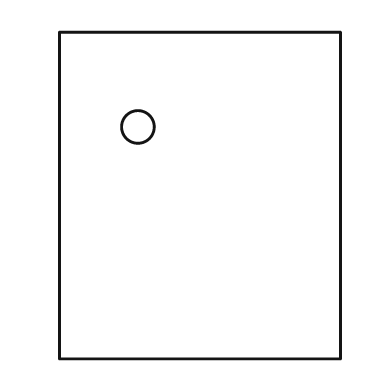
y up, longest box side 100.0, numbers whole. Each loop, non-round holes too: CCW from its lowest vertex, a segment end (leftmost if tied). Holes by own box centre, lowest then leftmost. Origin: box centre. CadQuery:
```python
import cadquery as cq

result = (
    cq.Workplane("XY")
    .moveTo(-43.0, -50.0)
    .lineTo(43.0, -50.0)
    .lineTo(43.0, 50.0)
    .lineTo(-43.0, 50.0)
    .close()
    .moveTo(-19.0, 21.0)
    .circle(5.0)
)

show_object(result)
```